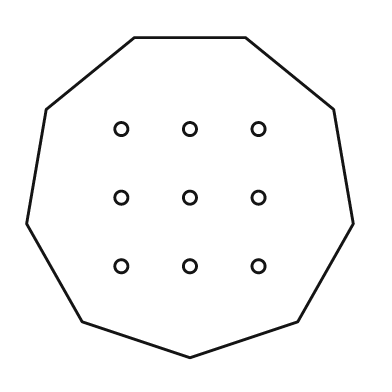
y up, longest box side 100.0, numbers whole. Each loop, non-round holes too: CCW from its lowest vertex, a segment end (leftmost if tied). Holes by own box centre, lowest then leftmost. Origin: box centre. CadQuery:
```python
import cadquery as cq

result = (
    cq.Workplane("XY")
    .moveTo(0.0, -49.0)
    .lineTo(33.0, -38.0)
    .lineTo(50.0, -8.0)
    .lineTo(44.0, 27.0)
    .lineTo(17.0, 49.0)
    .lineTo(-17.0, 49.0)
    .lineTo(-44.0, 27.0)
    .lineTo(-50.0, -8.0)
    .lineTo(-33.0, -38.0)
    .close()
    .moveTo(-21.0, -21.0)
    .circle(2.0)
    .moveTo(0.0, -21.0)
    .circle(2.0)
    .moveTo(21.0, -21.0)
    .circle(2.0)
    .moveTo(-21.0, 0.0)
    .circle(2.0)
    .moveTo(0.0, 0.0)
    .circle(2.0)
    .moveTo(21.0, 0.0)
    .circle(2.0)
    .moveTo(-21.0, 21.0)
    .circle(2.0)
    .moveTo(0.0, 21.0)
    .circle(2.0)
    .moveTo(21.0, 21.0)
    .circle(2.0)
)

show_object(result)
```